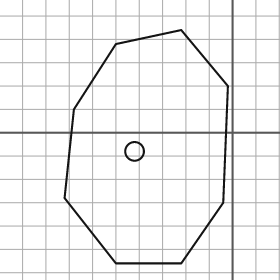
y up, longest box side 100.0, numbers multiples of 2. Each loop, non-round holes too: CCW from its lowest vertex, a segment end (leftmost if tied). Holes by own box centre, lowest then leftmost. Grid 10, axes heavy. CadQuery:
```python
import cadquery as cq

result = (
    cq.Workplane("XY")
    .moveTo(-50.0, -56.0)
    .lineTo(-22.0, -56.0)
    .lineTo(-4.0, -30.0)
    .lineTo(-2.0, 20.0)
    .lineTo(-22.0, 44.0)
    .lineTo(-50.0, 38.0)
    .lineTo(-68.0, 10.0)
    .lineTo(-72.0, -28.0)
    .close()
    .moveTo(-42.0, -8.0)
    .circle(4.0)
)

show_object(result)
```